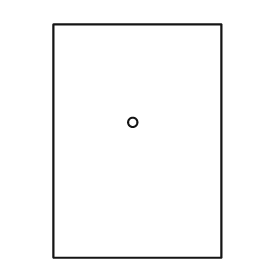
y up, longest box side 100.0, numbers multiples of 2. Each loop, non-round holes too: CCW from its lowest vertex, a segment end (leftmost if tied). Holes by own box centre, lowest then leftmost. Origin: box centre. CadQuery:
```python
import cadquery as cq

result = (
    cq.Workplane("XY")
    .moveTo(-36.0, -50.0)
    .lineTo(36.0, -50.0)
    .lineTo(36.0, 50.0)
    .lineTo(-36.0, 50.0)
    .close()
    .moveTo(-2.0, 8.0)
    .circle(2.0)
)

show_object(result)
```